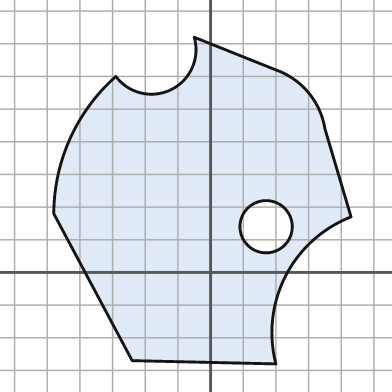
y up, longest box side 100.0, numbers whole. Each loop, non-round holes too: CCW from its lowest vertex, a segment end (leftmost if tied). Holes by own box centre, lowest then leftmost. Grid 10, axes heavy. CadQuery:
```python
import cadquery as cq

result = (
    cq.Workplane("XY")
    .moveTo(20.0, -28.0)
    .threePointArc((23.0, -1.0), (43.0, 17.0))
    .lineTo(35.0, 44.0)
    .threePointArc((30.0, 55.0), (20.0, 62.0))
    .lineTo(-5.0, 72.0)
    .threePointArc((-12.0, 56.0), (-29.0, 60.0))
    .threePointArc((-43.0, 41.0), (-48.0, 18.0))
    .lineTo(-24.0, -27.0)
    .close()
    .moveTo(17.0, 14.0)
    .circle(8.0)
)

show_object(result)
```